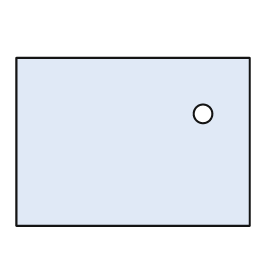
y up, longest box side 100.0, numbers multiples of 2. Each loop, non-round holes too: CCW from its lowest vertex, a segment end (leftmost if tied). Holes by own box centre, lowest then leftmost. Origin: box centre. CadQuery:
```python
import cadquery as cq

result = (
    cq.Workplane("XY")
    .moveTo(-50.0, -36.0)
    .lineTo(50.0, -36.0)
    .lineTo(50.0, 36.0)
    .lineTo(-50.0, 36.0)
    .close()
    .moveTo(30.0, 12.0)
    .circle(4.0)
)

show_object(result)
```